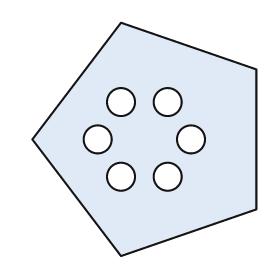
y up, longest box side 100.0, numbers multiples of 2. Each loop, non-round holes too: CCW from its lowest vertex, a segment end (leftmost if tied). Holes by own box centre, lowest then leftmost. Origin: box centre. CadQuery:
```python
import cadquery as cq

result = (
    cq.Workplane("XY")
    .moveTo(-10.0, -50.0)
    .lineTo(48.0, -30.0)
    .lineTo(48.0, 30.0)
    .lineTo(-10.0, 50.0)
    .lineTo(-48.0, 0.0)
    .close()
    .moveTo(-10.0, -16.0)
    .circle(6.0)
    .moveTo(10.0, -16.0)
    .circle(6.0)
    .moveTo(-20.0, 0.0)
    .circle(6.0)
    .moveTo(20.0, 0.0)
    .circle(6.0)
    .moveTo(-10.0, 16.0)
    .circle(6.0)
    .moveTo(10.0, 16.0)
    .circle(6.0)
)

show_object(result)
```